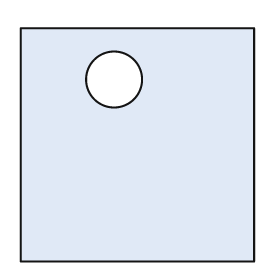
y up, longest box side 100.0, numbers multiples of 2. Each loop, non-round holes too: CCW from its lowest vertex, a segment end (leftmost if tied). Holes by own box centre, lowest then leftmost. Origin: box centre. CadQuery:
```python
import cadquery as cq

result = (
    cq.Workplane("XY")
    .moveTo(-50.0, -50.0)
    .lineTo(50.0, -50.0)
    .lineTo(50.0, 50.0)
    .lineTo(-50.0, 50.0)
    .close()
    .moveTo(-10.0, 28.0)
    .circle(12.0)
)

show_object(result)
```